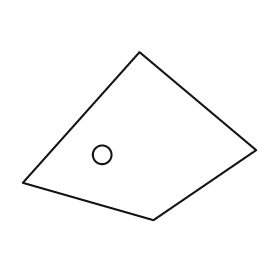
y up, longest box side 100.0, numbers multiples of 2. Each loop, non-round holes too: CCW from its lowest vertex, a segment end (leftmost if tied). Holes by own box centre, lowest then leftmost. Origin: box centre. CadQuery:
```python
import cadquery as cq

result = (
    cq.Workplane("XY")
    .moveTo(6.0, -36.0)
    .lineTo(50.0, -6.0)
    .lineTo(0.0, 36.0)
    .lineTo(-50.0, -20.0)
    .close()
    .moveTo(-16.0, -8.0)
    .circle(4.0)
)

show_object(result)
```